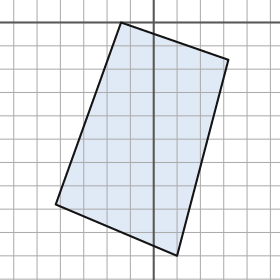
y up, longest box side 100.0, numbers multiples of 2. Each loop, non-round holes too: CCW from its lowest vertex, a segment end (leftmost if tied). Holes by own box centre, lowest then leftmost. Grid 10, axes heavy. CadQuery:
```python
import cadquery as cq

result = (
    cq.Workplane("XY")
    .moveTo(10.0, -100.0)
    .lineTo(32.0, -16.0)
    .lineTo(-14.0, 0.0)
    .lineTo(-42.0, -78.0)
    .close()
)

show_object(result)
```